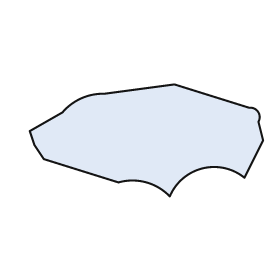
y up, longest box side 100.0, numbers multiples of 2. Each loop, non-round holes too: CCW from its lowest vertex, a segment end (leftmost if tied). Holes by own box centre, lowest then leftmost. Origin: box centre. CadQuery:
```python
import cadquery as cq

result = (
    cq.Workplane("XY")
    .moveTo(10.0, -24.0)
    .threePointArc((24.0, -12.0), (42.0, -16.0))
    .lineTo(50.0, 0.0)
    .lineTo(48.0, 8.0)
    .threePointArc((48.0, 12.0), (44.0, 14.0))
    .lineTo(12.0, 24.0)
    .lineTo(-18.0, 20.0)
    .threePointArc((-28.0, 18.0), (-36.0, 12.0))
    .lineTo(-50.0, 4.0)
    .lineTo(-48.0, -2.0)
    .lineTo(-44.0, -8.0)
    .lineTo(-12.0, -18.0)
    .threePointArc((0.0, -18.0), (10.0, -24.0))
    .close()
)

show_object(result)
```